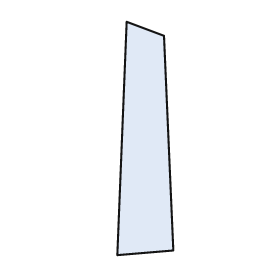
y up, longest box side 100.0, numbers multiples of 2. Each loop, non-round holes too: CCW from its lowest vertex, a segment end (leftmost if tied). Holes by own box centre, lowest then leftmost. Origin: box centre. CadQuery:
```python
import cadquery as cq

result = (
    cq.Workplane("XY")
    .moveTo(-12.0, -50.0)
    .lineTo(12.0, -48.0)
    .lineTo(8.0, 44.0)
    .lineTo(-8.0, 50.0)
    .close()
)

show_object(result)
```